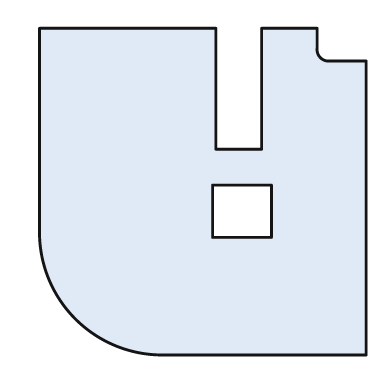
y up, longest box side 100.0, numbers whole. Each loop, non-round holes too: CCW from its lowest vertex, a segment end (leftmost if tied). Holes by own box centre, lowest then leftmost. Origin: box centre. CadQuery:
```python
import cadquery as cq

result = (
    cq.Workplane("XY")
    .moveTo(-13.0, -50.0)
    .lineTo(50.0, -50.0)
    .lineTo(50.0, 40.0)
    .lineTo(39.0, 40.0)
    .threePointArc((36.0, 41.0), (35.0, 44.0))
    .lineTo(35.0, 50.0)
    .lineTo(18.0, 50.0)
    .lineTo(18.0, 13.0)
    .lineTo(4.0, 13.0)
    .lineTo(4.0, 50.0)
    .lineTo(-50.0, 50.0)
    .lineTo(-50.0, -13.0)
    .threePointArc((-39.0, -39.0), (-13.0, -50.0))
    .close()
    .moveTo(3.0, -14.0)
    .lineTo(21.0, -14.0)
    .lineTo(21.0, 2.0)
    .lineTo(3.0, 2.0)
    .close()
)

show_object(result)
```